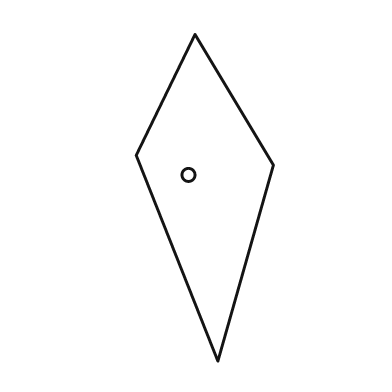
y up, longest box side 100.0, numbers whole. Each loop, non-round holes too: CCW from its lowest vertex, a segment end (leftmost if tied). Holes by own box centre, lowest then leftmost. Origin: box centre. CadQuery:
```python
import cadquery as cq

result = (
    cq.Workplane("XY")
    .moveTo(4.0, -50.0)
    .lineTo(21.0, 10.0)
    .lineTo(-3.0, 50.0)
    .lineTo(-21.0, 13.0)
    .close()
    .moveTo(-5.0, 7.0)
    .circle(2.0)
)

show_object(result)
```